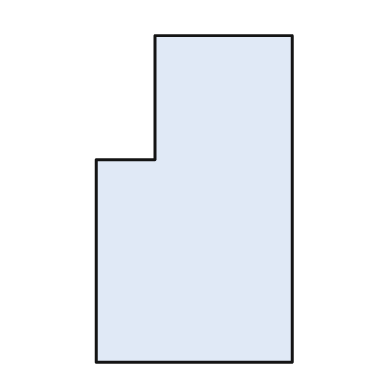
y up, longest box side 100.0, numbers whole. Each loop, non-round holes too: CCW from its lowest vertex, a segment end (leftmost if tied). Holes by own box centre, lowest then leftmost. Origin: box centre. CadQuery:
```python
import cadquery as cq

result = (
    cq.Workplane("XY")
    .moveTo(-30.0, -50.0)
    .lineTo(30.0, -50.0)
    .lineTo(30.0, 50.0)
    .lineTo(-12.0, 50.0)
    .lineTo(-12.0, 12.0)
    .lineTo(-30.0, 12.0)
    .close()
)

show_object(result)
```